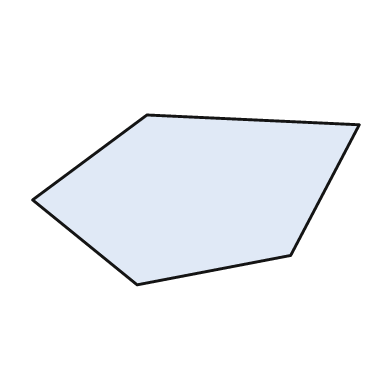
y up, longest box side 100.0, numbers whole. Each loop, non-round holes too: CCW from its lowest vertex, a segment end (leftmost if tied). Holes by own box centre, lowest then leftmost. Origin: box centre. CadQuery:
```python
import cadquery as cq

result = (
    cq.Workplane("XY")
    .moveTo(-18.0, -26.0)
    .lineTo(29.0, -17.0)
    .lineTo(50.0, 23.0)
    .lineTo(-15.0, 26.0)
    .lineTo(-50.0, 0.0)
    .close()
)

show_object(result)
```